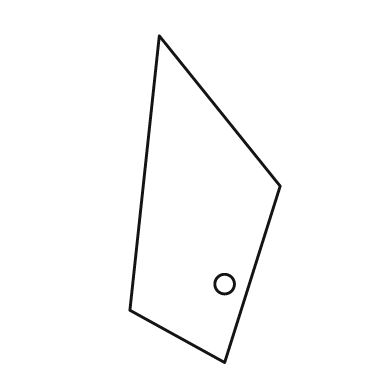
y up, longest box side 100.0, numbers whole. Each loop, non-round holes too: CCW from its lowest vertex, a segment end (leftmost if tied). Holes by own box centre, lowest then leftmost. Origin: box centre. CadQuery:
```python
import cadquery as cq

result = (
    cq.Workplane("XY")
    .moveTo(6.0, -50.0)
    .lineTo(23.0, 4.0)
    .lineTo(-14.0, 50.0)
    .lineTo(-23.0, -34.0)
    .close()
    .moveTo(6.0, -26.0)
    .circle(3.0)
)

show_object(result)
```